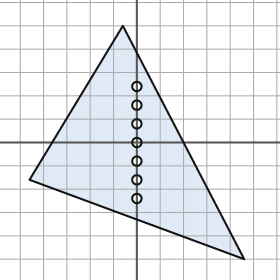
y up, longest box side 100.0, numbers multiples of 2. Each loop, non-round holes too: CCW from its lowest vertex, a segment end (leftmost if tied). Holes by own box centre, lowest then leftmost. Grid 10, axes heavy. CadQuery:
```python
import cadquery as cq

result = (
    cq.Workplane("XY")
    .moveTo(46.0, -50.0)
    .lineTo(-6.0, 50.0)
    .lineTo(-46.0, -16.0)
    .close()
    .moveTo(0.0, -24.0)
    .circle(2.0)
    .moveTo(0.0, -16.0)
    .circle(2.0)
    .moveTo(0.0, -8.0)
    .circle(2.0)
    .moveTo(0.0, 0.0)
    .circle(2.0)
    .moveTo(0.0, 8.0)
    .circle(2.0)
    .moveTo(0.0, 16.0)
    .circle(2.0)
    .moveTo(0.0, 24.0)
    .circle(2.0)
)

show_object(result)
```